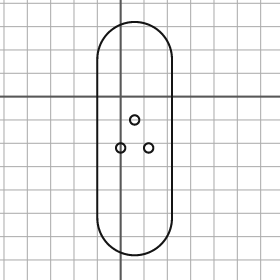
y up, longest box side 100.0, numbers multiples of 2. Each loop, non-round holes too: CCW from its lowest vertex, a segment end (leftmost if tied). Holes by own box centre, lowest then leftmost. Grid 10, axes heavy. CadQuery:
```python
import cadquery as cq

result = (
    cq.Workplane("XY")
    .moveTo(-10.0, -52.0)
    .threePointArc((6.0, -68.0), (22.0, -52.0))
    .lineTo(22.0, 16.0)
    .threePointArc((6.0, 32.0), (-10.0, 16.0))
    .close()
    .moveTo(0.0, -22.0)
    .circle(2.0)
    .moveTo(12.0, -22.0)
    .circle(2.0)
    .moveTo(6.0, -10.0)
    .circle(2.0)
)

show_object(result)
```